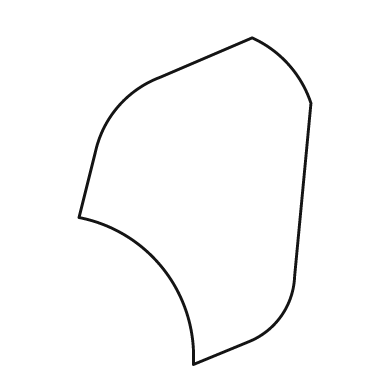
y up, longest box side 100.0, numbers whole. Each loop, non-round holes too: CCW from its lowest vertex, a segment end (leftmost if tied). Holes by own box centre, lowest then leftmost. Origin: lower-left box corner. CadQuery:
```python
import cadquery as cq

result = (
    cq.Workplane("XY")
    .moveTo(35.0, 0.0)
    .lineTo(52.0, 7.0)
    .threePointArc((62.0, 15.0), (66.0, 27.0))
    .lineTo(71.0, 80.0)
    .threePointArc((64.0, 92.0), (53.0, 100.0))
    .lineTo(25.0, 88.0)
    .threePointArc((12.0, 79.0), (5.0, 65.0))
    .lineTo(0.0, 45.0)
    .threePointArc((26.0, 29.0), (35.0, 0.0))
    .close()
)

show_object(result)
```